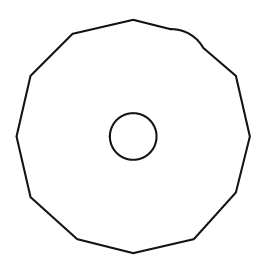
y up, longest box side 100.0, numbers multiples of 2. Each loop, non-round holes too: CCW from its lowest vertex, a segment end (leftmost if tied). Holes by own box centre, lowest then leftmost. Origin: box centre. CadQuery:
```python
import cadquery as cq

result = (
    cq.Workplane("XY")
    .moveTo(0.0, -50.0)
    .lineTo(26.0, -44.0)
    .lineTo(44.0, -24.0)
    .lineTo(50.0, 0.0)
    .lineTo(44.0, 26.0)
    .lineTo(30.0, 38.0)
    .threePointArc((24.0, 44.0), (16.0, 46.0))
    .lineTo(0.0, 50.0)
    .lineTo(-26.0, 44.0)
    .lineTo(-44.0, 26.0)
    .lineTo(-50.0, 0.0)
    .lineTo(-44.0, -26.0)
    .lineTo(-24.0, -44.0)
    .close()
    .moveTo(0.0, 0.0)
    .circle(10.0)
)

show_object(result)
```